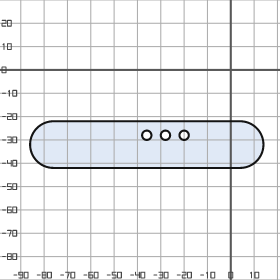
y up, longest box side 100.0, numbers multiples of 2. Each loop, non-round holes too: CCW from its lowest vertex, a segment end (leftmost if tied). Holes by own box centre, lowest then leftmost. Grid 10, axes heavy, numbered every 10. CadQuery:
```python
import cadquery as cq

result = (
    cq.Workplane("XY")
    .moveTo(-76.0, -42.0)
    .lineTo(4.0, -42.0)
    .threePointArc((14.0, -32.0), (4.0, -22.0))
    .lineTo(-76.0, -22.0)
    .threePointArc((-86.0, -32.0), (-76.0, -42.0))
    .close()
    .moveTo(-36.0, -28.0)
    .circle(2.0)
    .moveTo(-28.0, -28.0)
    .circle(2.0)
    .moveTo(-20.0, -28.0)
    .circle(2.0)
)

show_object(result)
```